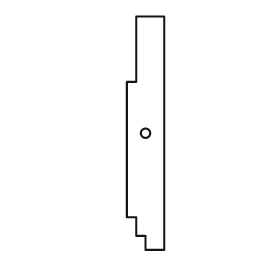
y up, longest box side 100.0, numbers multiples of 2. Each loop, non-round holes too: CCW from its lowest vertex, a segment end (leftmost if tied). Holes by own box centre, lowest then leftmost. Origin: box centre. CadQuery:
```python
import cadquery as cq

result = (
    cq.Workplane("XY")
    .moveTo(0.0, -50.0)
    .lineTo(8.0, -50.0)
    .lineTo(8.0, 50.0)
    .lineTo(-4.0, 50.0)
    .lineTo(-4.0, 22.0)
    .lineTo(-8.0, 22.0)
    .lineTo(-8.0, -36.0)
    .lineTo(-4.0, -36.0)
    .lineTo(-4.0, -44.0)
    .lineTo(0.0, -44.0)
    .close()
    .moveTo(0.0, 0.0)
    .circle(2.0)
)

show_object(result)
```